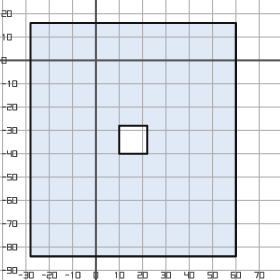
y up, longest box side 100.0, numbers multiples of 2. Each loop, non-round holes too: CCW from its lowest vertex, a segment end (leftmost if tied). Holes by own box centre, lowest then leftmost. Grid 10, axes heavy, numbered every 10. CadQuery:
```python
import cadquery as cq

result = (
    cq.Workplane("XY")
    .moveTo(-28.0, -84.0)
    .lineTo(60.0, -84.0)
    .lineTo(60.0, 16.0)
    .lineTo(-28.0, 16.0)
    .close()
    .moveTo(10.0, -40.0)
    .lineTo(22.0, -40.0)
    .lineTo(22.0, -28.0)
    .lineTo(10.0, -28.0)
    .close()
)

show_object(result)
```